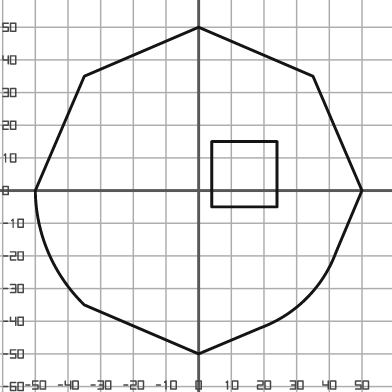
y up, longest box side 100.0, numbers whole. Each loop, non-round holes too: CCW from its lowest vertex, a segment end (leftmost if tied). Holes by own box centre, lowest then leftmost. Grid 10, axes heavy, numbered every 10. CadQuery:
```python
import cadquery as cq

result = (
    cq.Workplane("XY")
    .moveTo(0.0, -50.0)
    .lineTo(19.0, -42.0)
    .threePointArc((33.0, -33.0), (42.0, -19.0))
    .lineTo(50.0, 0.0)
    .lineTo(35.0, 35.0)
    .lineTo(0.0, 50.0)
    .lineTo(-35.0, 35.0)
    .lineTo(-50.0, 0.0)
    .threePointArc((-46.0, -19.0), (-35.0, -35.0))
    .close()
    .moveTo(4.0, -5.0)
    .lineTo(24.0, -5.0)
    .lineTo(24.0, 15.0)
    .lineTo(4.0, 15.0)
    .close()
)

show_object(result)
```